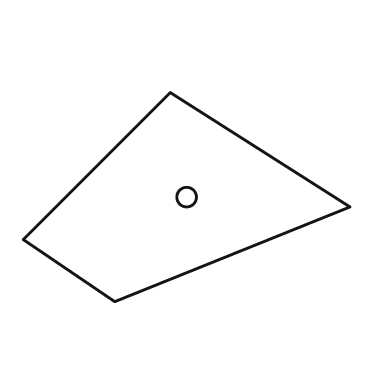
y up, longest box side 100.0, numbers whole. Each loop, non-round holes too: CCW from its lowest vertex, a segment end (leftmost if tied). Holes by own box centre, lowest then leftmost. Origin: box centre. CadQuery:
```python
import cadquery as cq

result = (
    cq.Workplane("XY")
    .moveTo(-22.0, -32.0)
    .lineTo(50.0, -3.0)
    .lineTo(-5.0, 32.0)
    .lineTo(-50.0, -13.0)
    .close()
    .moveTo(0.0, 0.0)
    .circle(3.0)
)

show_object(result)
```